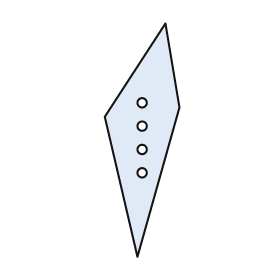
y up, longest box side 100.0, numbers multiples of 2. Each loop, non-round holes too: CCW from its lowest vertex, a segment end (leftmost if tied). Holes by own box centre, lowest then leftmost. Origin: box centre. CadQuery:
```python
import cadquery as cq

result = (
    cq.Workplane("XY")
    .moveTo(-2.0, -50.0)
    .lineTo(16.0, 14.0)
    .lineTo(10.0, 50.0)
    .lineTo(-16.0, 10.0)
    .close()
    .moveTo(0.0, -14.0)
    .circle(2.0)
    .moveTo(0.0, -4.0)
    .circle(2.0)
    .moveTo(0.0, 6.0)
    .circle(2.0)
    .moveTo(0.0, 16.0)
    .circle(2.0)
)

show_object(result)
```